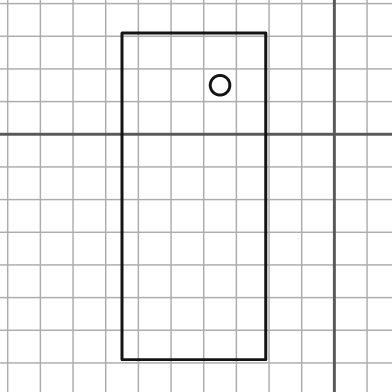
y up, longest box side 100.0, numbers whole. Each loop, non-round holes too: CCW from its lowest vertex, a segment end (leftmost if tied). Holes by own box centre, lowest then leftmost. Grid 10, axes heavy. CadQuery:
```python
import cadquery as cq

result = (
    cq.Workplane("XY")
    .moveTo(-65.0, -69.0)
    .lineTo(-21.0, -69.0)
    .lineTo(-21.0, 31.0)
    .lineTo(-65.0, 31.0)
    .close()
    .moveTo(-35.0, 15.0)
    .circle(3.0)
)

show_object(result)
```